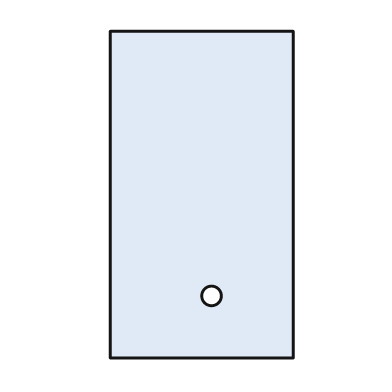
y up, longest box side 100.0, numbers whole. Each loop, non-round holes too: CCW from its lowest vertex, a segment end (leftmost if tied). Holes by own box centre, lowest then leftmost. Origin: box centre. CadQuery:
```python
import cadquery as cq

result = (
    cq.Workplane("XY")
    .moveTo(-28.0, -50.0)
    .lineTo(28.0, -50.0)
    .lineTo(28.0, 50.0)
    .lineTo(-28.0, 50.0)
    .close()
    .moveTo(3.0, -31.0)
    .circle(3.0)
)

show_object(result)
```